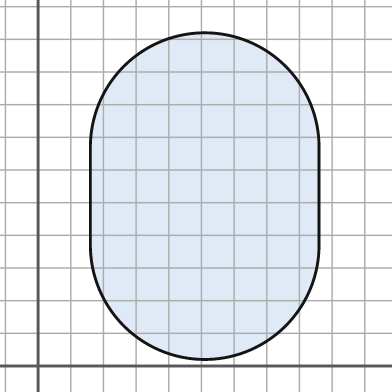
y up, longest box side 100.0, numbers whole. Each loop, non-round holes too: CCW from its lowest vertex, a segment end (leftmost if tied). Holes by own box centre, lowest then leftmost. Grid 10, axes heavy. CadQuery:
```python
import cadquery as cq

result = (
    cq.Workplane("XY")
    .moveTo(16.0, 37.0)
    .threePointArc((51.0, 2.0), (86.0, 37.0))
    .lineTo(86.0, 67.0)
    .threePointArc((51.0, 102.0), (16.0, 67.0))
    .close()
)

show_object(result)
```